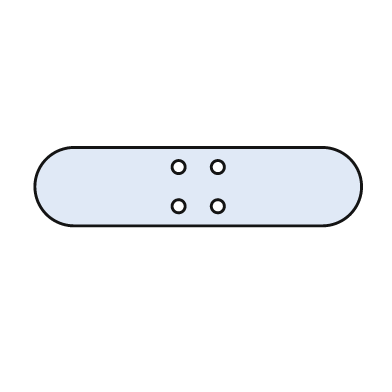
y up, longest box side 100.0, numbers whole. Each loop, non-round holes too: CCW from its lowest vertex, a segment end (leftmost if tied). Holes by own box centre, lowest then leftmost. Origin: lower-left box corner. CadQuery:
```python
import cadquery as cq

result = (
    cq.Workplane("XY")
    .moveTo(12.0, 0.0)
    .lineTo(88.0, 0.0)
    .threePointArc((100.0, 12.0), (88.0, 24.0))
    .lineTo(12.0, 24.0)
    .threePointArc((0.0, 12.0), (12.0, 0.0))
    .close()
    .moveTo(44.0, 6.0)
    .circle(2.0)
    .moveTo(56.0, 6.0)
    .circle(2.0)
    .moveTo(44.0, 18.0)
    .circle(2.0)
    .moveTo(56.0, 18.0)
    .circle(2.0)
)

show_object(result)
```